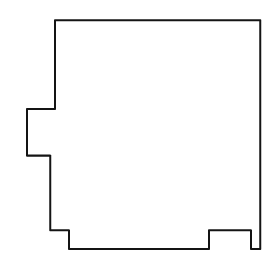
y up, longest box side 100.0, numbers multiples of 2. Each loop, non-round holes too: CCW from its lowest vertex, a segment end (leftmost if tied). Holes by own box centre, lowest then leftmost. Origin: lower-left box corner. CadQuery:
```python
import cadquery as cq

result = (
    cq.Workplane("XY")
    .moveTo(18.0, 0.0)
    .lineTo(78.0, 0.0)
    .lineTo(78.0, 8.0)
    .lineTo(96.0, 8.0)
    .lineTo(96.0, 0.0)
    .lineTo(100.0, 0.0)
    .lineTo(100.0, 98.0)
    .lineTo(12.0, 98.0)
    .lineTo(12.0, 60.0)
    .lineTo(0.0, 60.0)
    .lineTo(0.0, 40.0)
    .lineTo(10.0, 40.0)
    .lineTo(10.0, 8.0)
    .lineTo(18.0, 8.0)
    .close()
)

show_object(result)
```